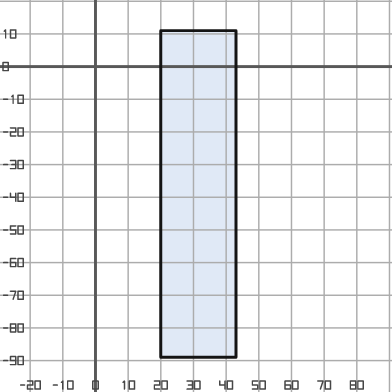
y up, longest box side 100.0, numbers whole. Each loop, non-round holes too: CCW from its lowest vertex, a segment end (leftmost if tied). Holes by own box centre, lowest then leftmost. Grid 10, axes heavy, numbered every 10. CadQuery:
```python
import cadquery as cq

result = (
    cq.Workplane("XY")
    .moveTo(20.0, -89.0)
    .lineTo(43.0, -89.0)
    .lineTo(43.0, 11.0)
    .lineTo(20.0, 11.0)
    .close()
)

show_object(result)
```